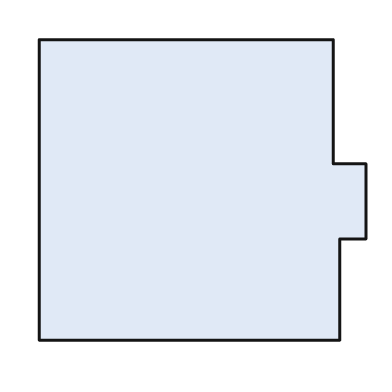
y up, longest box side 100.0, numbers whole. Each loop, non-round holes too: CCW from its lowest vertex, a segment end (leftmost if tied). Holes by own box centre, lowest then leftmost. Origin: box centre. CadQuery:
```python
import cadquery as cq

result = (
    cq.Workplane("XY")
    .moveTo(-50.0, -46.0)
    .lineTo(42.0, -46.0)
    .lineTo(42.0, -15.0)
    .lineTo(50.0, -15.0)
    .lineTo(50.0, 8.0)
    .lineTo(40.0, 8.0)
    .lineTo(40.0, 46.0)
    .lineTo(-50.0, 46.0)
    .close()
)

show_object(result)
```